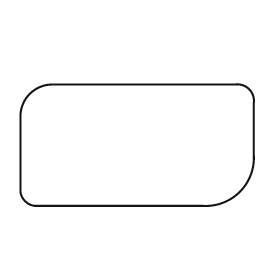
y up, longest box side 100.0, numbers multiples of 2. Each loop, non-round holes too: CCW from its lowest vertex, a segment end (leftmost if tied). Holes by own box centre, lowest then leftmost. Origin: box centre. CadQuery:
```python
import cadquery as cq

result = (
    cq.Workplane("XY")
    .moveTo(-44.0, -26.0)
    .lineTo(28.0, -26.0)
    .threePointArc((44.0, -20.0), (50.0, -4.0))
    .lineTo(50.0, 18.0)
    .threePointArc((48.0, 24.0), (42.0, 26.0))
    .lineTo(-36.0, 26.0)
    .threePointArc((-46.0, 22.0), (-50.0, 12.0))
    .lineTo(-50.0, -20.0)
    .threePointArc((-48.0, -24.0), (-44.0, -26.0))
    .close()
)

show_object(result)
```